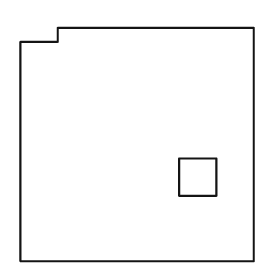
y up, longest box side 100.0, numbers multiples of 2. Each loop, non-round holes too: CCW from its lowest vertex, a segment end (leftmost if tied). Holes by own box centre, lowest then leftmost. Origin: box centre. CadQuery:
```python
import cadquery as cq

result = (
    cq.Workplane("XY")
    .moveTo(-50.0, -50.0)
    .lineTo(50.0, -50.0)
    .lineTo(50.0, 50.0)
    .lineTo(-34.0, 50.0)
    .lineTo(-34.0, 44.0)
    .lineTo(-50.0, 44.0)
    .close()
    .moveTo(18.0, -22.0)
    .lineTo(34.0, -22.0)
    .lineTo(34.0, -6.0)
    .lineTo(18.0, -6.0)
    .close()
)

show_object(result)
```